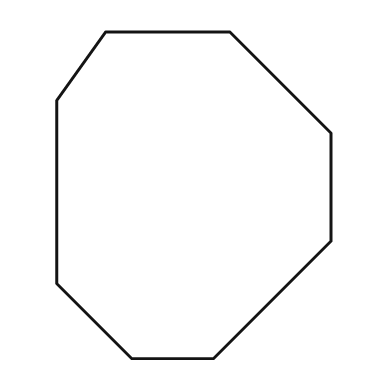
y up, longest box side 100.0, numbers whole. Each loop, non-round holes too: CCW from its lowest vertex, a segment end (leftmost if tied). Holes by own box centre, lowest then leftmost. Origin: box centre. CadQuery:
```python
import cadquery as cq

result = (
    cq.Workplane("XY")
    .moveTo(-19.0, -50.0)
    .lineTo(6.0, -50.0)
    .lineTo(42.0, -14.0)
    .lineTo(42.0, 19.0)
    .lineTo(11.0, 50.0)
    .lineTo(-27.0, 50.0)
    .lineTo(-42.0, 29.0)
    .lineTo(-42.0, -27.0)
    .close()
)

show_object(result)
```